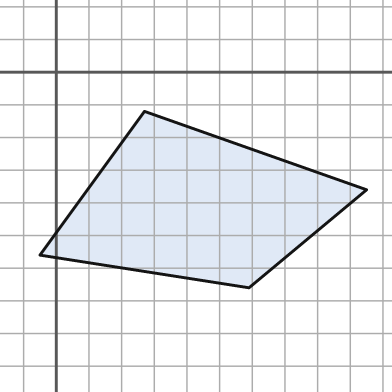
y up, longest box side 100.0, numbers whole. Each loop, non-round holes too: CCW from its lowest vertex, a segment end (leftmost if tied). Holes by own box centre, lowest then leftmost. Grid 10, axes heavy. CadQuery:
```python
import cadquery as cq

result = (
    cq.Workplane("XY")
    .moveTo(59.0, -66.0)
    .lineTo(95.0, -36.0)
    .lineTo(27.0, -12.0)
    .lineTo(-5.0, -56.0)
    .close()
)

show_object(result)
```